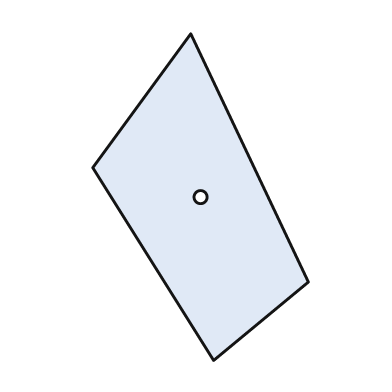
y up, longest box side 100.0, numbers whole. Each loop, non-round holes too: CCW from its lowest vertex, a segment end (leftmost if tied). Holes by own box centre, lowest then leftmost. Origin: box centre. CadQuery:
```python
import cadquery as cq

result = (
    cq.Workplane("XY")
    .moveTo(4.0, -50.0)
    .lineTo(33.0, -26.0)
    .lineTo(-3.0, 50.0)
    .lineTo(-33.0, 9.0)
    .close()
    .moveTo(0.0, 0.0)
    .circle(2.0)
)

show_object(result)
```